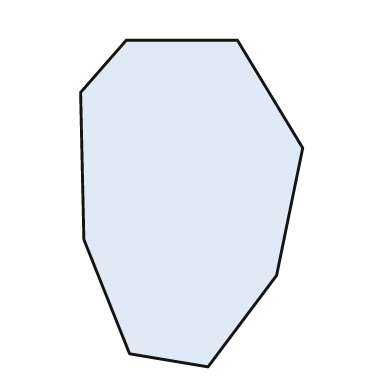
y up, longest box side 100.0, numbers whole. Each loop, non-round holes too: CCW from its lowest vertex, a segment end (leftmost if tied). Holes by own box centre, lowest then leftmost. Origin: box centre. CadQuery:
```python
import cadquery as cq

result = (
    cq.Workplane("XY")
    .moveTo(5.0, -50.0)
    .lineTo(26.0, -22.0)
    .lineTo(34.0, 17.0)
    .lineTo(14.0, 50.0)
    .lineTo(-20.0, 50.0)
    .lineTo(-34.0, 34.0)
    .lineTo(-33.0, -11.0)
    .lineTo(-19.0, -46.0)
    .close()
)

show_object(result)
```